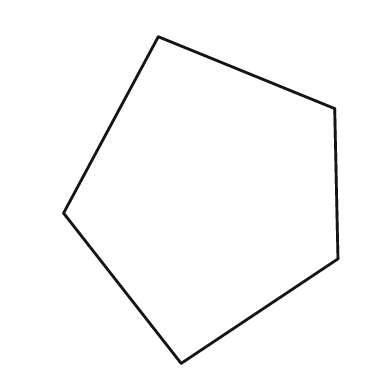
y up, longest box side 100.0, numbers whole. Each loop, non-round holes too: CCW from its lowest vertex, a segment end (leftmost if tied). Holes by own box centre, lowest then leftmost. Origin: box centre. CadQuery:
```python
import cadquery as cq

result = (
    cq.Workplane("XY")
    .moveTo(-6.0, -50.0)
    .lineTo(42.0, -18.0)
    .lineTo(41.0, 28.0)
    .lineTo(-13.0, 50.0)
    .lineTo(-42.0, -4.0)
    .close()
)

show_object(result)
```